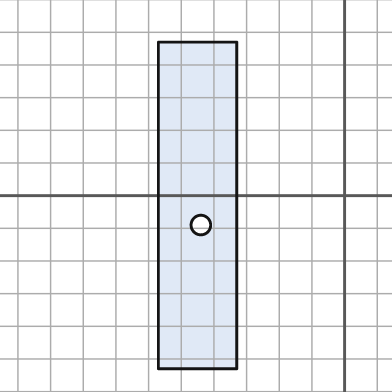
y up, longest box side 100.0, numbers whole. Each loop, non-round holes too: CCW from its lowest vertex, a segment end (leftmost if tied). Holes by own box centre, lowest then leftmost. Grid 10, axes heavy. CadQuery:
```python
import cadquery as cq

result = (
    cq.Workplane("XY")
    .moveTo(-57.0, -53.0)
    .lineTo(-33.0, -53.0)
    .lineTo(-33.0, 47.0)
    .lineTo(-57.0, 47.0)
    .close()
    .moveTo(-44.0, -9.0)
    .circle(3.0)
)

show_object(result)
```